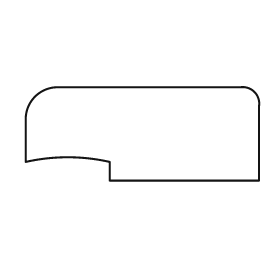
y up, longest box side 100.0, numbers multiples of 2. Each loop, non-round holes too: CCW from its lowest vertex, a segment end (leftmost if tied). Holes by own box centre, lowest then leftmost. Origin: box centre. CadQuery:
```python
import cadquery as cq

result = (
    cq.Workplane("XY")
    .moveTo(-14.0, -20.0)
    .lineTo(50.0, -20.0)
    .lineTo(50.0, 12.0)
    .threePointArc((48.0, 18.0), (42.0, 20.0))
    .lineTo(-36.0, 20.0)
    .threePointArc((-46.0, 16.0), (-50.0, 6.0))
    .lineTo(-50.0, -12.0)
    .threePointArc((-32.0, -10.0), (-14.0, -12.0))
    .close()
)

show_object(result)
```